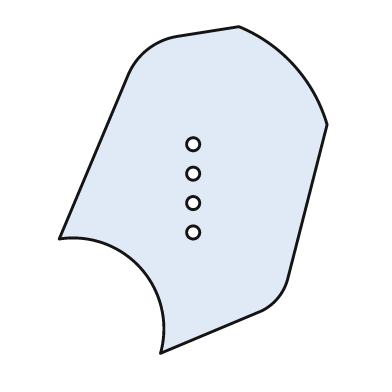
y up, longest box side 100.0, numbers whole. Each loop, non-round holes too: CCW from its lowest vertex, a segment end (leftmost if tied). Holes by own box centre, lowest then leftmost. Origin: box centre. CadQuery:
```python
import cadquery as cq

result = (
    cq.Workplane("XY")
    .moveTo(-10.0, -50.0)
    .lineTo(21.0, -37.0)
    .threePointArc((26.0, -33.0), (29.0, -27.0))
    .lineTo(41.0, 20.0)
    .threePointArc((31.0, 38.0), (14.0, 50.0))
    .lineTo(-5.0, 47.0)
    .threePointArc((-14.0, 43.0), (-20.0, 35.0))
    .lineTo(-41.0, -15.0)
    .threePointArc((-16.0, -24.0), (-10.0, -50.0))
    .close()
    .moveTo(0.0, -13.0)
    .circle(2.0)
    .moveTo(0.0, -4.0)
    .circle(2.0)
    .moveTo(0.0, 5.0)
    .circle(2.0)
    .moveTo(0.0, 14.0)
    .circle(2.0)
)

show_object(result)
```